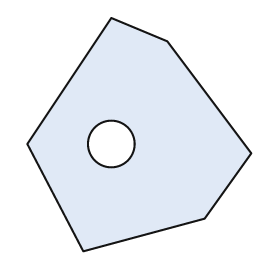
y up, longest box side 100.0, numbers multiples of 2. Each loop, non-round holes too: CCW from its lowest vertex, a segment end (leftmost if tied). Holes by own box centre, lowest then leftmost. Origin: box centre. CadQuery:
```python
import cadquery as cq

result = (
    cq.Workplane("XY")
    .moveTo(-24.0, -50.0)
    .lineTo(28.0, -36.0)
    .lineTo(48.0, -8.0)
    .lineTo(12.0, 40.0)
    .lineTo(-12.0, 50.0)
    .lineTo(-48.0, -4.0)
    .close()
    .moveTo(-12.0, -4.0)
    .circle(10.0)
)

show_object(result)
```